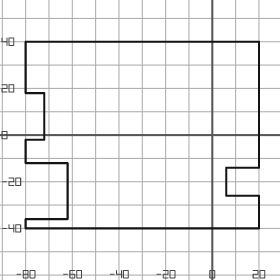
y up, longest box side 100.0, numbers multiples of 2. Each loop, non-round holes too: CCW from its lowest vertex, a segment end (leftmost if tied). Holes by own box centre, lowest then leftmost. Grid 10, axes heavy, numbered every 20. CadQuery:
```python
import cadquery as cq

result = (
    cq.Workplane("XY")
    .moveTo(-80.0, -40.0)
    .lineTo(20.0, -40.0)
    .lineTo(20.0, -26.0)
    .lineTo(6.0, -26.0)
    .lineTo(6.0, -14.0)
    .lineTo(20.0, -14.0)
    .lineTo(20.0, 40.0)
    .lineTo(-80.0, 40.0)
    .lineTo(-80.0, 18.0)
    .lineTo(-72.0, 18.0)
    .lineTo(-72.0, -2.0)
    .lineTo(-80.0, -2.0)
    .lineTo(-80.0, -12.0)
    .lineTo(-62.0, -12.0)
    .lineTo(-62.0, -36.0)
    .lineTo(-80.0, -36.0)
    .close()
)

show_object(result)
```